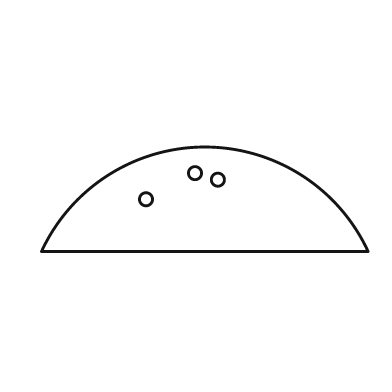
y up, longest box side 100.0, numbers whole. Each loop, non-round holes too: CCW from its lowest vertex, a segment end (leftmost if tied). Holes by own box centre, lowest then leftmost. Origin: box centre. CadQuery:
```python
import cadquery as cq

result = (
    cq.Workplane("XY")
    .moveTo(-50.0, -16.0)
    .lineTo(50.0, -16.0)
    .threePointArc((0.0, 16.0), (-50.0, -16.0))
    .close()
    .moveTo(-18.0, 0.0)
    .circle(2.0)
    .moveTo(4.0, 6.0)
    .circle(2.0)
    .moveTo(-3.0, 8.0)
    .circle(2.0)
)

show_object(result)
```